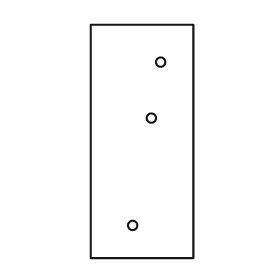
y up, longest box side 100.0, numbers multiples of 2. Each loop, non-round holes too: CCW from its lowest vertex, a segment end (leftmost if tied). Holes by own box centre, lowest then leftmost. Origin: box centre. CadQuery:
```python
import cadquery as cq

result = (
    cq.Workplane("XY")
    .moveTo(-22.0, -50.0)
    .lineTo(22.0, -50.0)
    .lineTo(22.0, 50.0)
    .lineTo(-22.0, 50.0)
    .close()
    .moveTo(-4.0, -36.0)
    .circle(2.0)
    .moveTo(4.0, 10.0)
    .circle(2.0)
    .moveTo(8.0, 34.0)
    .circle(2.0)
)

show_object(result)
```